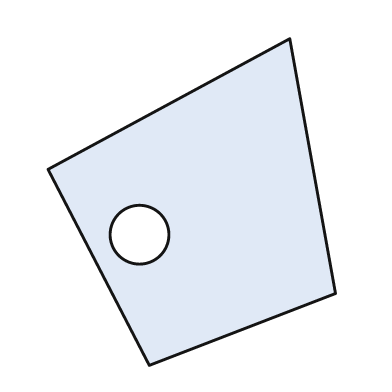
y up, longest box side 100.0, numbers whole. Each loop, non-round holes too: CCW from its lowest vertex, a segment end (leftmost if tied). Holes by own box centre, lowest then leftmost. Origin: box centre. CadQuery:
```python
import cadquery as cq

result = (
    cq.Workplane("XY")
    .moveTo(-13.0, -50.0)
    .lineTo(44.0, -28.0)
    .lineTo(30.0, 50.0)
    .lineTo(-44.0, 10.0)
    .close()
    .moveTo(-16.0, -10.0)
    .circle(9.0)
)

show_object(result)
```